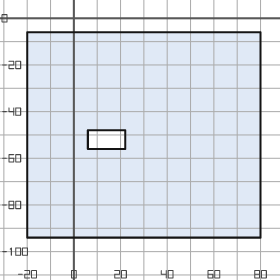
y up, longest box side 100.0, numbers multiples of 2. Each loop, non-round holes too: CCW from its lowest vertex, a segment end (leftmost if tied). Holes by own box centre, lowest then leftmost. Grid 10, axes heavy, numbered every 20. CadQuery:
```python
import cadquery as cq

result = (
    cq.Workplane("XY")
    .moveTo(-20.0, -94.0)
    .lineTo(80.0, -94.0)
    .lineTo(80.0, -6.0)
    .lineTo(-20.0, -6.0)
    .close()
    .moveTo(6.0, -56.0)
    .lineTo(22.0, -56.0)
    .lineTo(22.0, -48.0)
    .lineTo(6.0, -48.0)
    .close()
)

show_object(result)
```